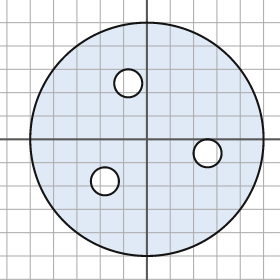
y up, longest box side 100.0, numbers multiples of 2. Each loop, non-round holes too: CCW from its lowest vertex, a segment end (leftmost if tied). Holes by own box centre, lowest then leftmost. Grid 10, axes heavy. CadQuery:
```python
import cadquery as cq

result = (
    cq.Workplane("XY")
    .moveTo(0.0, 0.0)
    .circle(50.0)
    .moveTo(-18.0, -18.0)
    .circle(6.0)
    .moveTo(26.0, -6.0)
    .circle(6.0)
    .moveTo(-8.0, 24.0)
    .circle(6.0)
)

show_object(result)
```